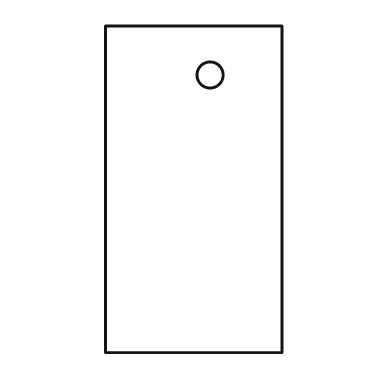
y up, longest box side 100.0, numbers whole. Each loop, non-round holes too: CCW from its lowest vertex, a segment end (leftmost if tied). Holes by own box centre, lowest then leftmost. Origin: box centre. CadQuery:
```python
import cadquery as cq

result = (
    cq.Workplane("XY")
    .moveTo(-27.0, -50.0)
    .lineTo(27.0, -50.0)
    .lineTo(27.0, 50.0)
    .lineTo(-27.0, 50.0)
    .close()
    .moveTo(5.0, 35.0)
    .circle(4.0)
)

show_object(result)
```